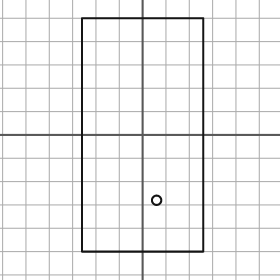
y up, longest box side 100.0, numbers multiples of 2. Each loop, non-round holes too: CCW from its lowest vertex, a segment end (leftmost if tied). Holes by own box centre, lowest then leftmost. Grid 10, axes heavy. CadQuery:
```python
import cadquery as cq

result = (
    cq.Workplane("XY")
    .moveTo(-26.0, -50.0)
    .lineTo(26.0, -50.0)
    .lineTo(26.0, 50.0)
    .lineTo(-26.0, 50.0)
    .close()
    .moveTo(6.0, -28.0)
    .circle(2.0)
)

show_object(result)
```